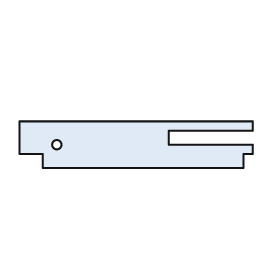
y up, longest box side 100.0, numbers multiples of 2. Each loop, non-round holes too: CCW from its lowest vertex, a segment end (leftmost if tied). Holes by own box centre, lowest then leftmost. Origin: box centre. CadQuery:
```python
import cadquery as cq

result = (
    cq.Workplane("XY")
    .moveTo(-40.0, -10.0)
    .lineTo(46.0, -10.0)
    .lineTo(46.0, -4.0)
    .lineTo(50.0, -4.0)
    .lineTo(50.0, 0.0)
    .lineTo(14.0, 0.0)
    .lineTo(14.0, 6.0)
    .lineTo(50.0, 6.0)
    .lineTo(50.0, 10.0)
    .lineTo(-50.0, 10.0)
    .lineTo(-50.0, -4.0)
    .lineTo(-40.0, -4.0)
    .close()
    .moveTo(-34.0, 0.0)
    .circle(2.0)
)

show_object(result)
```